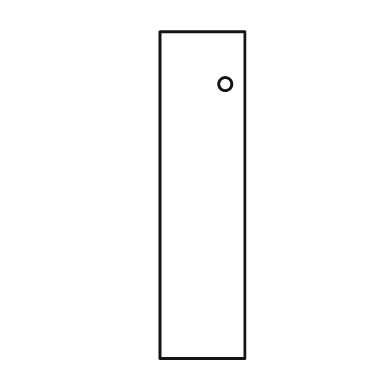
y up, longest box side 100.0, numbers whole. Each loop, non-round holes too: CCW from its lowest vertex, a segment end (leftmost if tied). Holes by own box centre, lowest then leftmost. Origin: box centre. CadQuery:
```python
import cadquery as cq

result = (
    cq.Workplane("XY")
    .moveTo(-13.0, -50.0)
    .lineTo(13.0, -50.0)
    .lineTo(13.0, 50.0)
    .lineTo(-13.0, 50.0)
    .close()
    .moveTo(7.0, 34.0)
    .circle(2.0)
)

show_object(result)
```